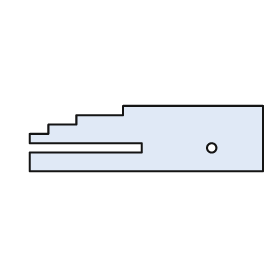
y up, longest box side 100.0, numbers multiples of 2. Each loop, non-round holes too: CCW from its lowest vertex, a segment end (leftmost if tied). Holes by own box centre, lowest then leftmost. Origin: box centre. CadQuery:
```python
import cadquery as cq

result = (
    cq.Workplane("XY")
    .moveTo(-50.0, -14.0)
    .lineTo(50.0, -14.0)
    .lineTo(50.0, 14.0)
    .lineTo(-10.0, 14.0)
    .lineTo(-10.0, 10.0)
    .lineTo(-30.0, 10.0)
    .lineTo(-30.0, 6.0)
    .lineTo(-42.0, 6.0)
    .lineTo(-42.0, 2.0)
    .lineTo(-50.0, 2.0)
    .lineTo(-50.0, -2.0)
    .lineTo(-2.0, -2.0)
    .lineTo(-2.0, -6.0)
    .lineTo(-50.0, -6.0)
    .close()
    .moveTo(28.0, -4.0)
    .circle(2.0)
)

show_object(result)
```